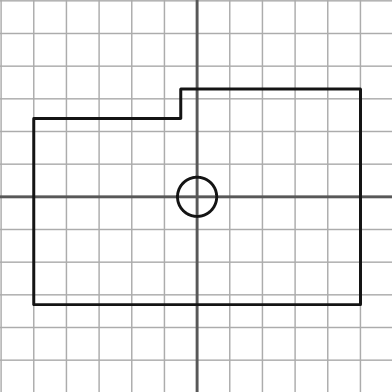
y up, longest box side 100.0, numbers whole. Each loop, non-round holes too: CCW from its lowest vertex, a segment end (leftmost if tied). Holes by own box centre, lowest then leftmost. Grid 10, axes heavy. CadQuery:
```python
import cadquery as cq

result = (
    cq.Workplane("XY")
    .moveTo(-50.0, -33.0)
    .lineTo(50.0, -33.0)
    .lineTo(50.0, 33.0)
    .lineTo(-5.0, 33.0)
    .lineTo(-5.0, 24.0)
    .lineTo(-50.0, 24.0)
    .close()
    .moveTo(0.0, 0.0)
    .circle(6.0)
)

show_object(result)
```